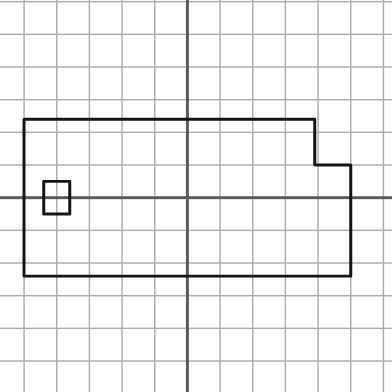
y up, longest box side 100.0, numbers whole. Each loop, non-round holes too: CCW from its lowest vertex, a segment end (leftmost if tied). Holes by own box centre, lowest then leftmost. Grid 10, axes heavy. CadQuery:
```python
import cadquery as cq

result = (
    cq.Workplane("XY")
    .moveTo(-50.0, -24.0)
    .lineTo(50.0, -24.0)
    .lineTo(50.0, 10.0)
    .lineTo(39.0, 10.0)
    .lineTo(39.0, 24.0)
    .lineTo(-50.0, 24.0)
    .close()
    .moveTo(-44.0, -5.0)
    .lineTo(-36.0, -5.0)
    .lineTo(-36.0, 5.0)
    .lineTo(-44.0, 5.0)
    .close()
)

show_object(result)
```